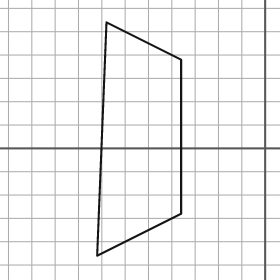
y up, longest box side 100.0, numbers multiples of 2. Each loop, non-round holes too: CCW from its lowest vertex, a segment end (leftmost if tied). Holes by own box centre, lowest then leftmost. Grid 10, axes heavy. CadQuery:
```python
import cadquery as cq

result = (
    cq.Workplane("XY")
    .moveTo(-72.0, -46.0)
    .lineTo(-36.0, -28.0)
    .lineTo(-36.0, 38.0)
    .lineTo(-68.0, 54.0)
    .close()
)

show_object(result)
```